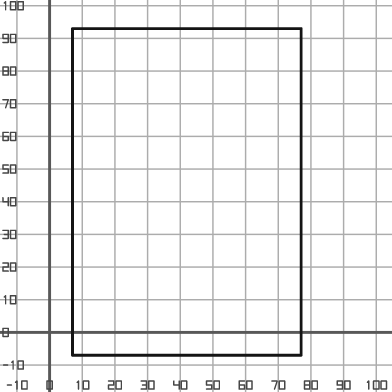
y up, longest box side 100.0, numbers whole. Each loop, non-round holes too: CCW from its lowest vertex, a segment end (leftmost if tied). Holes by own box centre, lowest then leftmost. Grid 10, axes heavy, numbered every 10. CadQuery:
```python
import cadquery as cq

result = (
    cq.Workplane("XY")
    .moveTo(7.0, -7.0)
    .lineTo(77.0, -7.0)
    .lineTo(77.0, 93.0)
    .lineTo(7.0, 93.0)
    .close()
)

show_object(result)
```